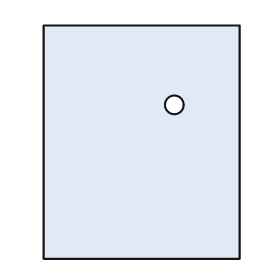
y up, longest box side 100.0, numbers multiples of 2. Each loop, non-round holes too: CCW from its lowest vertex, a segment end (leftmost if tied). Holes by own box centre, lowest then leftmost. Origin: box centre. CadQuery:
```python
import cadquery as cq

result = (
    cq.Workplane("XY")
    .moveTo(-42.0, -50.0)
    .lineTo(42.0, -50.0)
    .lineTo(42.0, 50.0)
    .lineTo(-42.0, 50.0)
    .close()
    .moveTo(14.0, 16.0)
    .circle(4.0)
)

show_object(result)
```